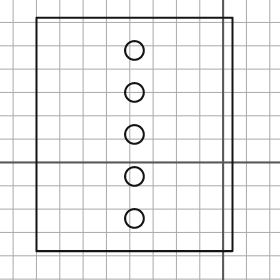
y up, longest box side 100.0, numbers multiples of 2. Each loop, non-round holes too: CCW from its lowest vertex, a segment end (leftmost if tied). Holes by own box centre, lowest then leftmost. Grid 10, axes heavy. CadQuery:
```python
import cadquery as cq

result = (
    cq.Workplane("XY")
    .moveTo(-80.0, -38.0)
    .lineTo(4.0, -38.0)
    .lineTo(4.0, 62.0)
    .lineTo(-80.0, 62.0)
    .close()
    .moveTo(-38.0, -24.0)
    .circle(4.0)
    .moveTo(-38.0, -6.0)
    .circle(4.0)
    .moveTo(-38.0, 12.0)
    .circle(4.0)
    .moveTo(-38.0, 30.0)
    .circle(4.0)
    .moveTo(-38.0, 48.0)
    .circle(4.0)
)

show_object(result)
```